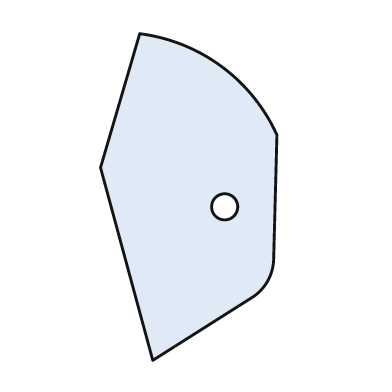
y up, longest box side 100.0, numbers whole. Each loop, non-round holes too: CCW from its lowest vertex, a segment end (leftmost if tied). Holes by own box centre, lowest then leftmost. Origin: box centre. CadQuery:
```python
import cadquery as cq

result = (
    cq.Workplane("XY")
    .moveTo(-11.0, -50.0)
    .lineTo(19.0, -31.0)
    .threePointArc((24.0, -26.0), (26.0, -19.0))
    .lineTo(27.0, 19.0)
    .threePointArc((10.0, 40.0), (-15.0, 50.0))
    .lineTo(-27.0, 9.0)
    .close()
    .moveTo(11.0, -3.0)
    .circle(4.0)
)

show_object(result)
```